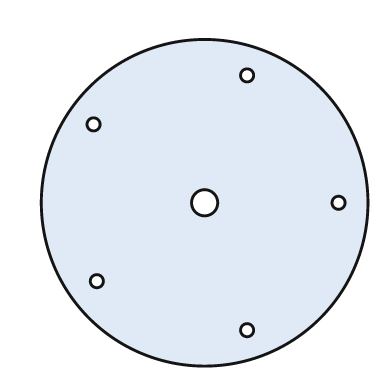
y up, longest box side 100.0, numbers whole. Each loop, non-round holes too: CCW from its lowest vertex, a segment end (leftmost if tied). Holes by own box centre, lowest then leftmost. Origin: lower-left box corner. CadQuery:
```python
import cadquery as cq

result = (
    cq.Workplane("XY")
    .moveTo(50.0, 50.0)
    .circle(50.0)
    .moveTo(63.0, 11.0)
    .circle(2.0)
    .moveTo(17.0, 26.0)
    .circle(2.0)
    .moveTo(50.0, 50.0)
    .circle(4.0)
    .moveTo(91.0, 50.0)
    .circle(2.0)
    .moveTo(16.0, 74.0)
    .circle(2.0)
    .moveTo(63.0, 89.0)
    .circle(2.0)
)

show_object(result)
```